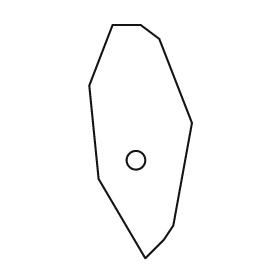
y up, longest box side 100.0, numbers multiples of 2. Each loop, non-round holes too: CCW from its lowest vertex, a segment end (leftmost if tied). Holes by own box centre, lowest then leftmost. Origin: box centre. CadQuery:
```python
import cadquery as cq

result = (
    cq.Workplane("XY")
    .moveTo(2.0, -50.0)
    .lineTo(10.0, -42.0)
    .lineTo(14.0, -36.0)
    .lineTo(22.0, 8.0)
    .lineTo(8.0, 44.0)
    .lineTo(0.0, 50.0)
    .lineTo(-12.0, 50.0)
    .lineTo(-22.0, 24.0)
    .lineTo(-18.0, -16.0)
    .close()
    .moveTo(-2.0, -8.0)
    .circle(4.0)
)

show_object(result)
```